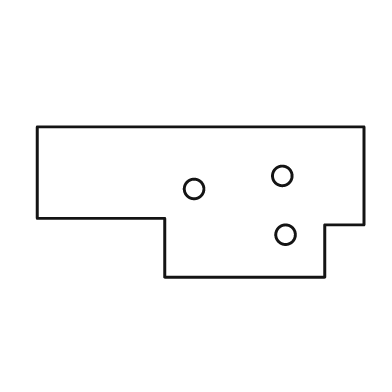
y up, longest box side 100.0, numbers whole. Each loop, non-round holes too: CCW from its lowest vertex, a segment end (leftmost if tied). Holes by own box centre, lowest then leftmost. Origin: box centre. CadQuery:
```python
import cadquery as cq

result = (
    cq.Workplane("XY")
    .moveTo(-11.0, -23.0)
    .lineTo(38.0, -23.0)
    .lineTo(38.0, -7.0)
    .lineTo(50.0, -7.0)
    .lineTo(50.0, 23.0)
    .lineTo(-50.0, 23.0)
    .lineTo(-50.0, -5.0)
    .lineTo(-11.0, -5.0)
    .close()
    .moveTo(26.0, -10.0)
    .circle(3.0)
    .moveTo(-2.0, 4.0)
    .circle(3.0)
    .moveTo(25.0, 8.0)
    .circle(3.0)
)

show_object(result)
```